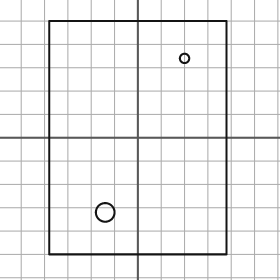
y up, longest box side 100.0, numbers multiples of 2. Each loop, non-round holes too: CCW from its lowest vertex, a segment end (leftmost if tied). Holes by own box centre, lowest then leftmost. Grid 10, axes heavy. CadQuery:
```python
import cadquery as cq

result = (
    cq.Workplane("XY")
    .moveTo(-38.0, -50.0)
    .lineTo(38.0, -50.0)
    .lineTo(38.0, 50.0)
    .lineTo(-38.0, 50.0)
    .close()
    .moveTo(-14.0, -32.0)
    .circle(4.0)
    .moveTo(20.0, 34.0)
    .circle(2.0)
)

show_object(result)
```